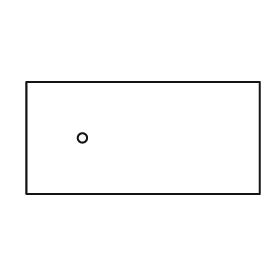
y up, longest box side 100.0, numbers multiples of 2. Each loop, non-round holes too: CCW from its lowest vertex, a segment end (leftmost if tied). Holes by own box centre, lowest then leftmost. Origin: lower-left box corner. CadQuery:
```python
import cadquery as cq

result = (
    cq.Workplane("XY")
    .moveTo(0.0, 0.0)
    .lineTo(100.0, 0.0)
    .lineTo(100.0, 48.0)
    .lineTo(0.0, 48.0)
    .close()
    .moveTo(24.0, 24.0)
    .circle(2.0)
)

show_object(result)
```